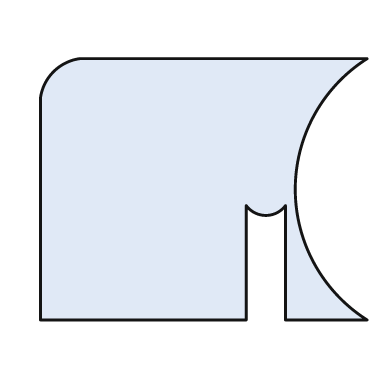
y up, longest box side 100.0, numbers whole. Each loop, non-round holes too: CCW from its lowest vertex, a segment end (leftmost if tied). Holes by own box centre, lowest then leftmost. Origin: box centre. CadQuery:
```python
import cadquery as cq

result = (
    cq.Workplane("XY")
    .moveTo(-50.0, -40.0)
    .lineTo(13.0, -40.0)
    .lineTo(13.0, -5.0)
    .threePointArc((19.0, -8.0), (25.0, -5.0))
    .lineTo(25.0, -40.0)
    .lineTo(50.0, -40.0)
    .threePointArc((28.0, 0.0), (50.0, 40.0))
    .lineTo(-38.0, 40.0)
    .threePointArc((-46.0, 36.0), (-50.0, 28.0))
    .close()
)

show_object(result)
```